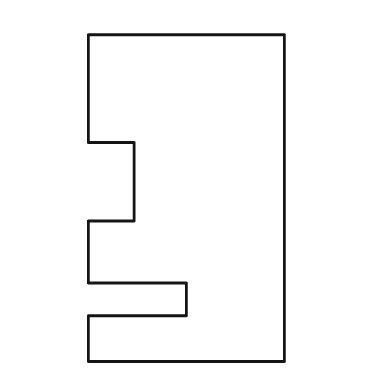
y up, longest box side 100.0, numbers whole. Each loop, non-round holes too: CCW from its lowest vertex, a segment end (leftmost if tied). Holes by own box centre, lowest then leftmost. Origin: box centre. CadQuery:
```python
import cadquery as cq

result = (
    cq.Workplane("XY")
    .moveTo(-30.0, -50.0)
    .lineTo(30.0, -50.0)
    .lineTo(30.0, 50.0)
    .lineTo(-30.0, 50.0)
    .lineTo(-30.0, 17.0)
    .lineTo(-16.0, 17.0)
    .lineTo(-16.0, -7.0)
    .lineTo(-30.0, -7.0)
    .lineTo(-30.0, -26.0)
    .lineTo(0.0, -26.0)
    .lineTo(0.0, -36.0)
    .lineTo(-30.0, -36.0)
    .close()
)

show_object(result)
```